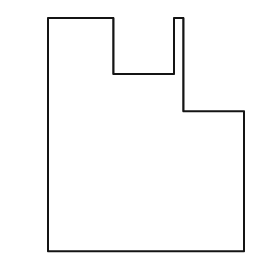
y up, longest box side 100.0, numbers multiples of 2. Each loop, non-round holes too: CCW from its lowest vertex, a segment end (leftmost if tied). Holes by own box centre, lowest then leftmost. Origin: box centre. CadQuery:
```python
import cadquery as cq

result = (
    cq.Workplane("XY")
    .moveTo(-42.0, -50.0)
    .lineTo(42.0, -50.0)
    .lineTo(42.0, 10.0)
    .lineTo(16.0, 10.0)
    .lineTo(16.0, 50.0)
    .lineTo(12.0, 50.0)
    .lineTo(12.0, 26.0)
    .lineTo(-14.0, 26.0)
    .lineTo(-14.0, 50.0)
    .lineTo(-42.0, 50.0)
    .close()
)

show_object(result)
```